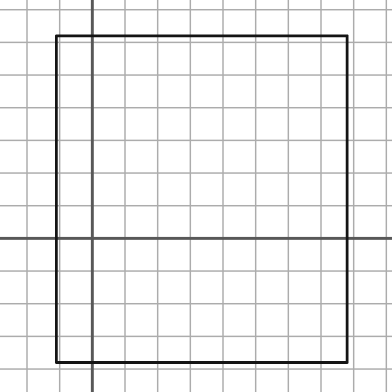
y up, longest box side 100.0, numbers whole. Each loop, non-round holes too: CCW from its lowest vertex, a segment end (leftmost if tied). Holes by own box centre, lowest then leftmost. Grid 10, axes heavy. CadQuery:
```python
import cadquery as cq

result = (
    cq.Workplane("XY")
    .moveTo(-11.0, -38.0)
    .lineTo(78.0, -38.0)
    .lineTo(78.0, 62.0)
    .lineTo(-11.0, 62.0)
    .close()
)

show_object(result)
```